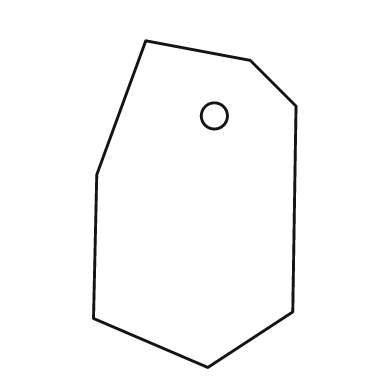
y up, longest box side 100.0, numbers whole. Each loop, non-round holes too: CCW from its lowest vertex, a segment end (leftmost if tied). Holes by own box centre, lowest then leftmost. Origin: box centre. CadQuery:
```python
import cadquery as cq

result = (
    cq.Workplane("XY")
    .moveTo(4.0, -50.0)
    .lineTo(30.0, -33.0)
    .lineTo(31.0, 30.0)
    .lineTo(17.0, 44.0)
    .lineTo(-15.0, 50.0)
    .lineTo(-30.0, 9.0)
    .lineTo(-31.0, -35.0)
    .close()
    .moveTo(6.0, 27.0)
    .circle(4.0)
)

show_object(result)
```